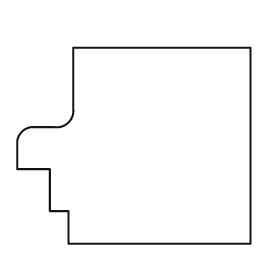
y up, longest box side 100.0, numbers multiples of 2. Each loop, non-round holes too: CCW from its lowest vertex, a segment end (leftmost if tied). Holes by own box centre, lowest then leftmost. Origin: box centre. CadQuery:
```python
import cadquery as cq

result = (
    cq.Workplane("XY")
    .moveTo(-28.0, -42.0)
    .lineTo(50.0, -42.0)
    .lineTo(50.0, 42.0)
    .lineTo(-26.0, 42.0)
    .lineTo(-26.0, 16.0)
    .threePointArc((-28.0, 10.0), (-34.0, 8.0))
    .lineTo(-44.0, 8.0)
    .threePointArc((-48.0, 6.0), (-50.0, 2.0))
    .lineTo(-50.0, -10.0)
    .lineTo(-36.0, -10.0)
    .lineTo(-36.0, -28.0)
    .lineTo(-28.0, -28.0)
    .close()
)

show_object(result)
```